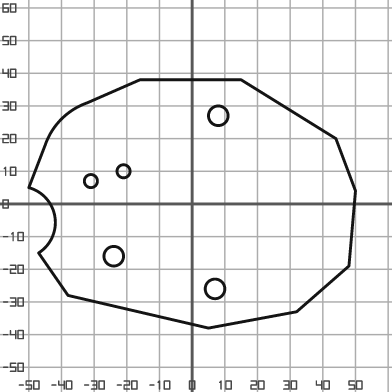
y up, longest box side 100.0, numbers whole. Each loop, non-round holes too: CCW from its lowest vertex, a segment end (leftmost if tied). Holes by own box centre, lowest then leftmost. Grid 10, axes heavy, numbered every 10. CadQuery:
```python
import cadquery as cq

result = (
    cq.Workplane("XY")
    .moveTo(5.0, -38.0)
    .lineTo(32.0, -33.0)
    .lineTo(48.0, -19.0)
    .lineTo(50.0, 4.0)
    .lineTo(44.0, 20.0)
    .lineTo(15.0, 38.0)
    .lineTo(-16.0, 38.0)
    .lineTo(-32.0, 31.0)
    .threePointArc((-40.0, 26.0), (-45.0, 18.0))
    .lineTo(-50.0, 5.0)
    .threePointArc((-42.0, -4.0), (-47.0, -15.0))
    .lineTo(-38.0, -28.0)
    .close()
    .moveTo(7.0, -26.0)
    .circle(3.0)
    .moveTo(-24.0, -16.0)
    .circle(3.0)
    .moveTo(-31.0, 7.0)
    .circle(2.0)
    .moveTo(-21.0, 10.0)
    .circle(2.0)
    .moveTo(8.0, 27.0)
    .circle(3.0)
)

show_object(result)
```